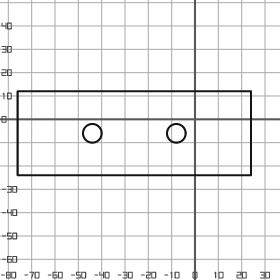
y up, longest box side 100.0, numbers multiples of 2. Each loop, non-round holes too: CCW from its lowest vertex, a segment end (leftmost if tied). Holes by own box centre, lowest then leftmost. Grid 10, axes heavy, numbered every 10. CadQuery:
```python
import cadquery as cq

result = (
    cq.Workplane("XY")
    .moveTo(-76.0, -24.0)
    .lineTo(24.0, -24.0)
    .lineTo(24.0, 12.0)
    .lineTo(-76.0, 12.0)
    .close()
    .moveTo(-44.0, -6.0)
    .circle(4.0)
    .moveTo(-8.0, -6.0)
    .circle(4.0)
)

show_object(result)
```